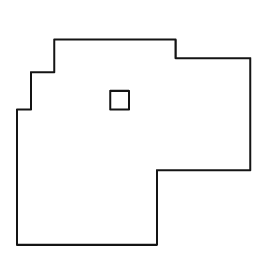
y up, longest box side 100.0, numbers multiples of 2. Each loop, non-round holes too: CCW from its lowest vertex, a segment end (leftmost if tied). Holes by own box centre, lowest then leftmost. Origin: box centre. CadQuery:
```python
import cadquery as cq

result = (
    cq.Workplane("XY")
    .moveTo(-50.0, -44.0)
    .lineTo(10.0, -44.0)
    .lineTo(10.0, -12.0)
    .lineTo(50.0, -12.0)
    .lineTo(50.0, 36.0)
    .lineTo(18.0, 36.0)
    .lineTo(18.0, 44.0)
    .lineTo(-34.0, 44.0)
    .lineTo(-34.0, 30.0)
    .lineTo(-44.0, 30.0)
    .lineTo(-44.0, 14.0)
    .lineTo(-50.0, 14.0)
    .close()
    .moveTo(-10.0, 14.0)
    .lineTo(-2.0, 14.0)
    .lineTo(-2.0, 22.0)
    .lineTo(-10.0, 22.0)
    .close()
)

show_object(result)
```